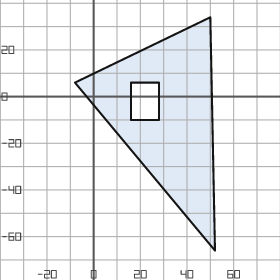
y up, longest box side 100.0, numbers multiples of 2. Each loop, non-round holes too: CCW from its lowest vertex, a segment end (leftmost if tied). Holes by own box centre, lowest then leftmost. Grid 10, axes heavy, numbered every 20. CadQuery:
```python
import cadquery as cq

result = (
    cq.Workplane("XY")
    .moveTo(52.0, -66.0)
    .lineTo(50.0, 34.0)
    .lineTo(-8.0, 6.0)
    .close()
    .moveTo(16.0, -10.0)
    .lineTo(28.0, -10.0)
    .lineTo(28.0, 6.0)
    .lineTo(16.0, 6.0)
    .close()
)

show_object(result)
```